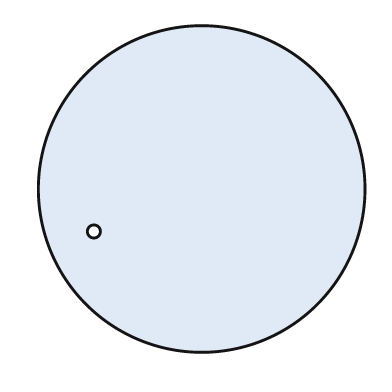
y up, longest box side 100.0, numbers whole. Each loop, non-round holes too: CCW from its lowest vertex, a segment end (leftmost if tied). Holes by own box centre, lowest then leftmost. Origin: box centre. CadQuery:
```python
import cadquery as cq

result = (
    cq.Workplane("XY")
    .moveTo(0.0, 0.0)
    .circle(50.0)
    .moveTo(-33.0, -13.0)
    .circle(2.0)
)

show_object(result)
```